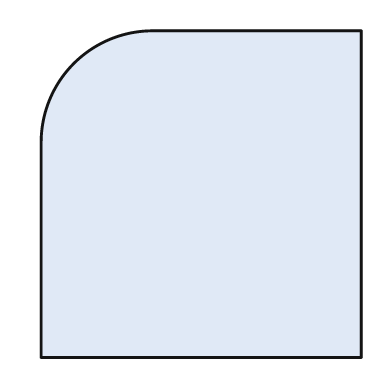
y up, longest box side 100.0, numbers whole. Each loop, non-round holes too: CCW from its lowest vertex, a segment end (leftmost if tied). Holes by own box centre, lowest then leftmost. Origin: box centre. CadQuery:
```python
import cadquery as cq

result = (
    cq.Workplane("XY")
    .moveTo(-49.0, -50.0)
    .lineTo(49.0, -50.0)
    .lineTo(49.0, 50.0)
    .lineTo(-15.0, 50.0)
    .threePointArc((-39.0, 40.0), (-49.0, 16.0))
    .close()
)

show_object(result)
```